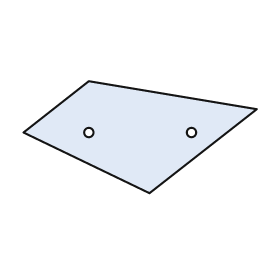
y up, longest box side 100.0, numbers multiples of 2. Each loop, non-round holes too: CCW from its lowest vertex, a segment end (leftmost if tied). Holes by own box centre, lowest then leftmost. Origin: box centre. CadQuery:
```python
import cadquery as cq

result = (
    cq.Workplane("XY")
    .moveTo(4.0, -24.0)
    .lineTo(50.0, 12.0)
    .lineTo(-22.0, 24.0)
    .lineTo(-50.0, 2.0)
    .close()
    .moveTo(-22.0, 2.0)
    .circle(2.0)
    .moveTo(22.0, 2.0)
    .circle(2.0)
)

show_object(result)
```